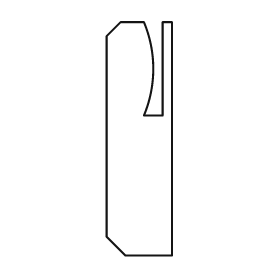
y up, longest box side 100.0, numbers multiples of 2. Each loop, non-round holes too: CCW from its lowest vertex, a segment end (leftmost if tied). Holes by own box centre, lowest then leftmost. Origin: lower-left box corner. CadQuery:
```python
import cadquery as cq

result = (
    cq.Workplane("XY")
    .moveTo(8.0, 0.0)
    .lineTo(28.0, 0.0)
    .lineTo(28.0, 100.0)
    .lineTo(24.0, 100.0)
    .lineTo(24.0, 60.0)
    .lineTo(16.0, 60.0)
    .threePointArc((20.0, 80.0), (16.0, 100.0))
    .lineTo(6.0, 100.0)
    .lineTo(0.0, 94.0)
    .lineTo(0.0, 8.0)
    .close()
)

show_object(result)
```